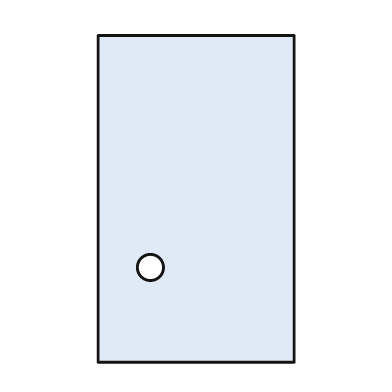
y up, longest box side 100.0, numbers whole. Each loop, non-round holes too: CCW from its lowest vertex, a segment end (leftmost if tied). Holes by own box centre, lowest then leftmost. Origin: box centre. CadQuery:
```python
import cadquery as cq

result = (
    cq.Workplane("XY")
    .moveTo(-30.0, -50.0)
    .lineTo(30.0, -50.0)
    .lineTo(30.0, 50.0)
    .lineTo(-30.0, 50.0)
    .close()
    .moveTo(-14.0, -21.0)
    .circle(4.0)
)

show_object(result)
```